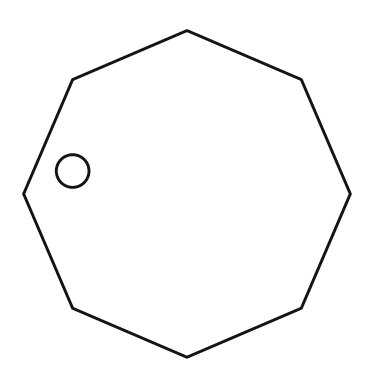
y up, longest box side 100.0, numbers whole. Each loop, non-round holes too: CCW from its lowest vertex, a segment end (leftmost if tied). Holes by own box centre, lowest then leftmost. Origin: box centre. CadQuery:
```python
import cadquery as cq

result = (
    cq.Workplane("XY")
    .moveTo(0.0, -50.0)
    .lineTo(35.0, -35.0)
    .lineTo(50.0, 0.0)
    .lineTo(35.0, 35.0)
    .lineTo(0.0, 50.0)
    .lineTo(-35.0, 35.0)
    .lineTo(-50.0, 0.0)
    .lineTo(-35.0, -35.0)
    .close()
    .moveTo(-35.0, 7.0)
    .circle(5.0)
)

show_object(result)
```